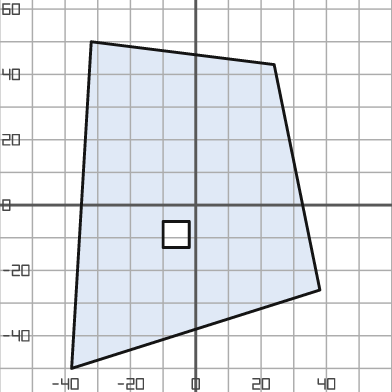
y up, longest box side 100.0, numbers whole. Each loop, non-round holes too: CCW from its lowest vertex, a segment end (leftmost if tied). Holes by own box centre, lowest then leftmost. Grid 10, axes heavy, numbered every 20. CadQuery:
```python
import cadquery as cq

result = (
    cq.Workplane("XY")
    .moveTo(-38.0, -50.0)
    .lineTo(38.0, -26.0)
    .lineTo(24.0, 43.0)
    .lineTo(-32.0, 50.0)
    .close()
    .moveTo(-10.0, -13.0)
    .lineTo(-2.0, -13.0)
    .lineTo(-2.0, -5.0)
    .lineTo(-10.0, -5.0)
    .close()
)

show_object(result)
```